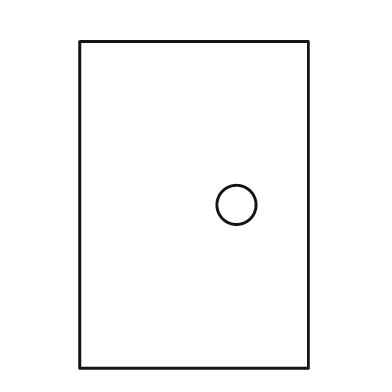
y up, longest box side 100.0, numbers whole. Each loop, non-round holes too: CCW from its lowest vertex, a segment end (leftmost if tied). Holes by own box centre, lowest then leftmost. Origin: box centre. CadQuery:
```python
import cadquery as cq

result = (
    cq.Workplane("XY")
    .moveTo(-35.0, -50.0)
    .lineTo(35.0, -50.0)
    .lineTo(35.0, 50.0)
    .lineTo(-35.0, 50.0)
    .close()
    .moveTo(13.0, 0.0)
    .circle(6.0)
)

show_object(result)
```